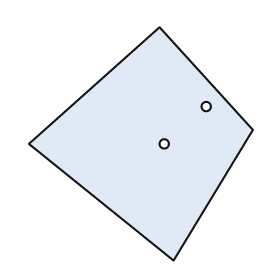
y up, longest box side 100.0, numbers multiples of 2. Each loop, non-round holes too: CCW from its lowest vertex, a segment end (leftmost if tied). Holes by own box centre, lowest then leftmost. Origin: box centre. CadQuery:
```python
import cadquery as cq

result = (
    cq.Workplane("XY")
    .moveTo(14.0, -50.0)
    .lineTo(48.0, 6.0)
    .lineTo(8.0, 50.0)
    .lineTo(-48.0, 0.0)
    .close()
    .moveTo(10.0, 0.0)
    .circle(2.0)
    .moveTo(28.0, 16.0)
    .circle(2.0)
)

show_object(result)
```